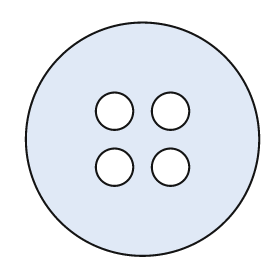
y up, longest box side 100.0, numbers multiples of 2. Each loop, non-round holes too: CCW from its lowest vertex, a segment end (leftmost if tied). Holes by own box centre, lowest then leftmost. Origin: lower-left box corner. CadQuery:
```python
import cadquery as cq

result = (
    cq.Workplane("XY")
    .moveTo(50.0, 50.0)
    .circle(50.0)
    .moveTo(38.0, 38.0)
    .circle(8.0)
    .moveTo(62.0, 38.0)
    .circle(8.0)
    .moveTo(38.0, 62.0)
    .circle(8.0)
    .moveTo(62.0, 62.0)
    .circle(8.0)
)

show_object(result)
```